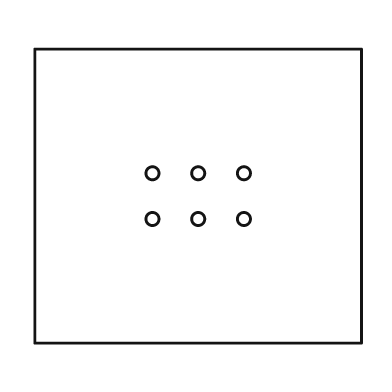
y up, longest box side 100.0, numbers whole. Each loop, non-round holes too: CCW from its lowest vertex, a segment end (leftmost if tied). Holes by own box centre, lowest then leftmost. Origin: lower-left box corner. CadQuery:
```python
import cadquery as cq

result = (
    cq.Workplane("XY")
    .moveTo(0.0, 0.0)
    .lineTo(100.0, 0.0)
    .lineTo(100.0, 90.0)
    .lineTo(0.0, 90.0)
    .close()
    .moveTo(36.0, 38.0)
    .circle(2.0)
    .moveTo(50.0, 38.0)
    .circle(2.0)
    .moveTo(64.0, 38.0)
    .circle(2.0)
    .moveTo(36.0, 52.0)
    .circle(2.0)
    .moveTo(50.0, 52.0)
    .circle(2.0)
    .moveTo(64.0, 52.0)
    .circle(2.0)
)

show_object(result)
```